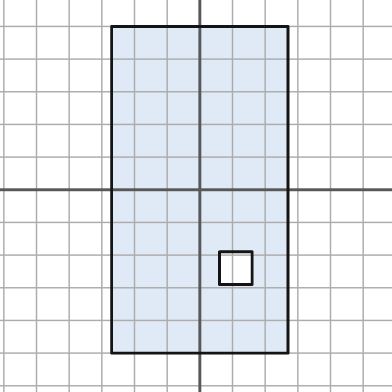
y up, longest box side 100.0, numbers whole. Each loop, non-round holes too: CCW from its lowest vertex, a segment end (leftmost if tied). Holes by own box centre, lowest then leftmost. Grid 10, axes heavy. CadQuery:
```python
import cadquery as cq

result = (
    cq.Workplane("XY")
    .moveTo(-27.0, -50.0)
    .lineTo(27.0, -50.0)
    .lineTo(27.0, 50.0)
    .lineTo(-27.0, 50.0)
    .close()
    .moveTo(6.0, -29.0)
    .lineTo(16.0, -29.0)
    .lineTo(16.0, -19.0)
    .lineTo(6.0, -19.0)
    .close()
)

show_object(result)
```